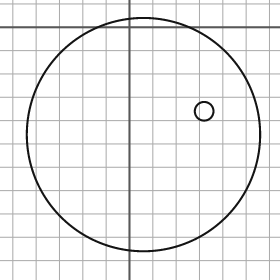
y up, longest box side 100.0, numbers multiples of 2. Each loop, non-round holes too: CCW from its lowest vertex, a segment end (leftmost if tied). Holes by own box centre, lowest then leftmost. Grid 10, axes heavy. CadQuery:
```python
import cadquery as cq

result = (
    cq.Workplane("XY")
    .moveTo(6.0, -46.0)
    .circle(50.0)
    .moveTo(32.0, -36.0)
    .circle(4.0)
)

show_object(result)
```